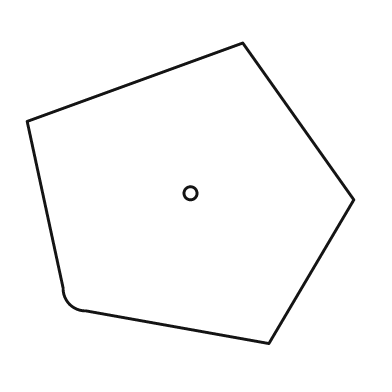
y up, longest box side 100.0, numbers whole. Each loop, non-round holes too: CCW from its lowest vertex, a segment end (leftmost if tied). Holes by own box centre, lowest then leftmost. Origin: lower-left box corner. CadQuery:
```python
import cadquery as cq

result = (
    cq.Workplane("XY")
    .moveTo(74.0, 0.0)
    .lineTo(100.0, 44.0)
    .lineTo(66.0, 92.0)
    .lineTo(0.0, 68.0)
    .lineTo(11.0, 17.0)
    .threePointArc((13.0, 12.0), (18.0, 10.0))
    .close()
    .moveTo(50.0, 46.0)
    .circle(2.0)
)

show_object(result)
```